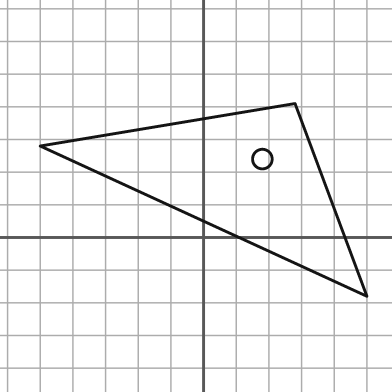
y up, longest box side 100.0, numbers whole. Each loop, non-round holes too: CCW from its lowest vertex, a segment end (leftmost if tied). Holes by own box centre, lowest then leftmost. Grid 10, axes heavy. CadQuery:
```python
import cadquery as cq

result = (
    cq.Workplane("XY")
    .moveTo(50.0, -18.0)
    .lineTo(28.0, 41.0)
    .lineTo(-50.0, 28.0)
    .close()
    .moveTo(18.0, 24.0)
    .circle(3.0)
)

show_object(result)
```